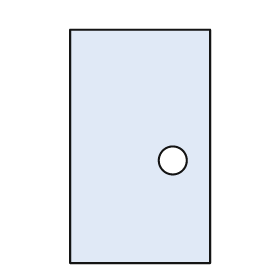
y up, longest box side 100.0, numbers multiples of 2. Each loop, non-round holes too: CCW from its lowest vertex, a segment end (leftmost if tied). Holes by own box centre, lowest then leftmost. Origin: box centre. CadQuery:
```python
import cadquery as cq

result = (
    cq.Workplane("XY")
    .moveTo(-30.0, -50.0)
    .lineTo(30.0, -50.0)
    .lineTo(30.0, 50.0)
    .lineTo(-30.0, 50.0)
    .close()
    .moveTo(14.0, -6.0)
    .circle(6.0)
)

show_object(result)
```